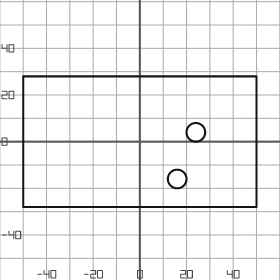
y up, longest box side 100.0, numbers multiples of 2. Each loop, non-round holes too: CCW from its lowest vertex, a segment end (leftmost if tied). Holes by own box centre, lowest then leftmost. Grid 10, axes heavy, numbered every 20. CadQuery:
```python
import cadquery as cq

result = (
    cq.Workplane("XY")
    .moveTo(-50.0, -28.0)
    .lineTo(50.0, -28.0)
    .lineTo(50.0, 28.0)
    .lineTo(-50.0, 28.0)
    .close()
    .moveTo(16.0, -16.0)
    .circle(4.0)
    .moveTo(24.0, 4.0)
    .circle(4.0)
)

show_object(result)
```